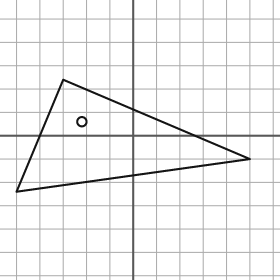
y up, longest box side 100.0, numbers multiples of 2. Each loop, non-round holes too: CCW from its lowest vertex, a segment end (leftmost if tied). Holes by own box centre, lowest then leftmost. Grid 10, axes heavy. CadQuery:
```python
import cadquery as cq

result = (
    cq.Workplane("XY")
    .moveTo(-50.0, -24.0)
    .lineTo(50.0, -10.0)
    .lineTo(-30.0, 24.0)
    .close()
    .moveTo(-22.0, 6.0)
    .circle(2.0)
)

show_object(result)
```